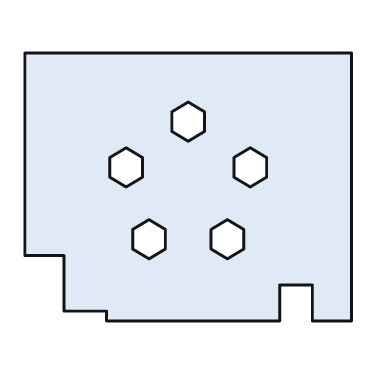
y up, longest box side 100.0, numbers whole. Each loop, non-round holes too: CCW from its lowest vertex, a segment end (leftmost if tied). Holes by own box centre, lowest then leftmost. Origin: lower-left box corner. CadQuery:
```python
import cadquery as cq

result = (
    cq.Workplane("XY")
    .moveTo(25.0, 0.0)
    .lineTo(78.0, 0.0)
    .lineTo(78.0, 11.0)
    .lineTo(88.0, 11.0)
    .lineTo(88.0, 0.0)
    .lineTo(100.0, 0.0)
    .lineTo(100.0, 82.0)
    .lineTo(0.0, 82.0)
    .lineTo(0.0, 20.0)
    .lineTo(12.0, 20.0)
    .lineTo(12.0, 3.0)
    .lineTo(25.0, 3.0)
    .close()
    .moveTo(38.0, 19.0)
    .lineTo(43.0, 22.0)
    .lineTo(43.0, 28.0)
    .lineTo(38.0, 31.0)
    .lineTo(33.0, 28.0)
    .lineTo(33.0, 22.0)
    .close()
    .moveTo(62.0, 19.0)
    .lineTo(67.0, 22.0)
    .lineTo(67.0, 28.0)
    .lineTo(62.0, 31.0)
    .lineTo(57.0, 28.0)
    .lineTo(57.0, 22.0)
    .close()
    .moveTo(31.0, 41.0)
    .lineTo(36.0, 44.0)
    .lineTo(36.0, 50.0)
    .lineTo(31.0, 53.0)
    .lineTo(26.0, 50.0)
    .lineTo(26.0, 44.0)
    .close()
    .moveTo(69.0, 41.0)
    .lineTo(74.0, 44.0)
    .lineTo(74.0, 50.0)
    .lineTo(69.0, 53.0)
    .lineTo(64.0, 50.0)
    .lineTo(64.0, 44.0)
    .close()
    .moveTo(50.0, 55.0)
    .lineTo(55.0, 58.0)
    .lineTo(55.0, 64.0)
    .lineTo(50.0, 67.0)
    .lineTo(45.0, 64.0)
    .lineTo(45.0, 58.0)
    .close()
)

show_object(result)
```